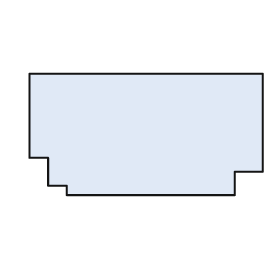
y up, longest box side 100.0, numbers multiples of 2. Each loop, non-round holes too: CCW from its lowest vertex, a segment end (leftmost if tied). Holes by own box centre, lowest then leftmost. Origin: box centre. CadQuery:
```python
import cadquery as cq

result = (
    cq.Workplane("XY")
    .moveTo(-34.0, -26.0)
    .lineTo(38.0, -26.0)
    .lineTo(38.0, -16.0)
    .lineTo(50.0, -16.0)
    .lineTo(50.0, 26.0)
    .lineTo(-50.0, 26.0)
    .lineTo(-50.0, -10.0)
    .lineTo(-42.0, -10.0)
    .lineTo(-42.0, -22.0)
    .lineTo(-34.0, -22.0)
    .close()
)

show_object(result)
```